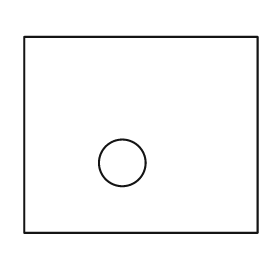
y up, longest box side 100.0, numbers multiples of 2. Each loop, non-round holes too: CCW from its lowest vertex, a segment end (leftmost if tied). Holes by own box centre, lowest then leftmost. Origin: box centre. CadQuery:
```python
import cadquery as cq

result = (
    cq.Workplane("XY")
    .moveTo(-50.0, -42.0)
    .lineTo(50.0, -42.0)
    .lineTo(50.0, 42.0)
    .lineTo(-50.0, 42.0)
    .close()
    .moveTo(-8.0, -12.0)
    .circle(10.0)
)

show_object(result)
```